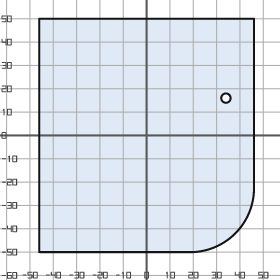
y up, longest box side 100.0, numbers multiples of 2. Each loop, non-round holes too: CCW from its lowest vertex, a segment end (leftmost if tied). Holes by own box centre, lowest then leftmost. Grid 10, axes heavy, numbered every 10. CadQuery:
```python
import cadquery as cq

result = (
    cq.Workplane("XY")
    .moveTo(-46.0, -50.0)
    .lineTo(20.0, -50.0)
    .threePointArc((38.0, -42.0), (46.0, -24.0))
    .lineTo(46.0, 50.0)
    .lineTo(-46.0, 50.0)
    .close()
    .moveTo(34.0, 16.0)
    .circle(2.0)
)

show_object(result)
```